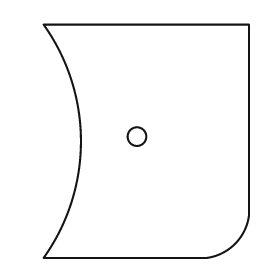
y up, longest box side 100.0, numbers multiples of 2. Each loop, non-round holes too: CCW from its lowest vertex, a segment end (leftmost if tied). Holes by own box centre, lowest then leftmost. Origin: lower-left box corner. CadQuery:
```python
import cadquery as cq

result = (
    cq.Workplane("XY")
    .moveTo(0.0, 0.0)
    .lineTo(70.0, 0.0)
    .threePointArc((82.0, 6.0), (88.0, 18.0))
    .lineTo(88.0, 100.0)
    .lineTo(0.0, 100.0)
    .threePointArc((16.0, 50.0), (0.0, 0.0))
    .close()
    .moveTo(40.0, 52.0)
    .circle(4.0)
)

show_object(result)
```